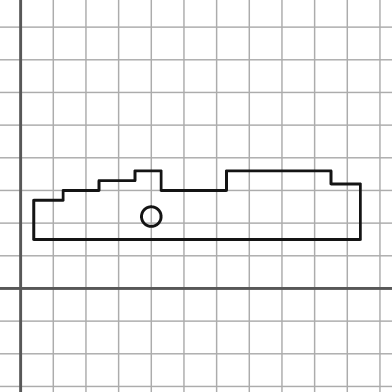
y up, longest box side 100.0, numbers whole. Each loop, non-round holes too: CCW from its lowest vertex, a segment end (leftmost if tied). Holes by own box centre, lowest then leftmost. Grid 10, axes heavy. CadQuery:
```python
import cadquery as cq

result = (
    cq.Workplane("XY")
    .moveTo(4.0, 15.0)
    .lineTo(104.0, 15.0)
    .lineTo(104.0, 32.0)
    .lineTo(95.0, 32.0)
    .lineTo(95.0, 36.0)
    .lineTo(63.0, 36.0)
    .lineTo(63.0, 30.0)
    .lineTo(43.0, 30.0)
    .lineTo(43.0, 36.0)
    .lineTo(35.0, 36.0)
    .lineTo(35.0, 33.0)
    .lineTo(24.0, 33.0)
    .lineTo(24.0, 30.0)
    .lineTo(13.0, 30.0)
    .lineTo(13.0, 27.0)
    .lineTo(4.0, 27.0)
    .close()
    .moveTo(40.0, 22.0)
    .circle(3.0)
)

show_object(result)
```